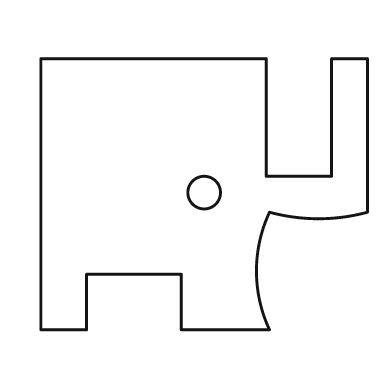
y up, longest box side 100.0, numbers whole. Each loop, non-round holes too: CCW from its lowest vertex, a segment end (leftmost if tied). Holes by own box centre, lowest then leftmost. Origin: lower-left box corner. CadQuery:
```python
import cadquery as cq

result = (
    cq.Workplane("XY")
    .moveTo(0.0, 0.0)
    .lineTo(14.0, 0.0)
    .lineTo(14.0, 17.0)
    .lineTo(43.0, 17.0)
    .lineTo(43.0, 0.0)
    .lineTo(70.0, 0.0)
    .threePointArc((66.0, 18.0), (70.0, 36.0))
    .threePointArc((85.0, 34.0), (100.0, 36.0))
    .lineTo(100.0, 83.0)
    .lineTo(89.0, 83.0)
    .lineTo(89.0, 47.0)
    .lineTo(69.0, 47.0)
    .lineTo(69.0, 83.0)
    .lineTo(0.0, 83.0)
    .close()
    .moveTo(50.0, 42.0)
    .circle(5.0)
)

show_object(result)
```